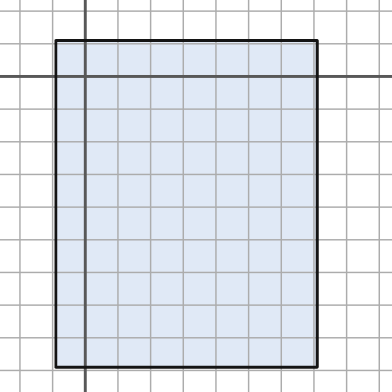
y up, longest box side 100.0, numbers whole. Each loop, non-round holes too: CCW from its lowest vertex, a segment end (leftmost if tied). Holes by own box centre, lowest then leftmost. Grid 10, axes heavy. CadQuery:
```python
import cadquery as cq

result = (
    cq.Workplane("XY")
    .moveTo(-9.0, -89.0)
    .lineTo(71.0, -89.0)
    .lineTo(71.0, 11.0)
    .lineTo(-9.0, 11.0)
    .close()
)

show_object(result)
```